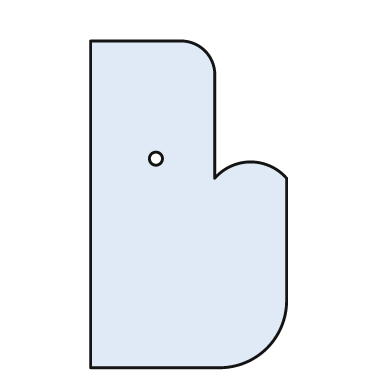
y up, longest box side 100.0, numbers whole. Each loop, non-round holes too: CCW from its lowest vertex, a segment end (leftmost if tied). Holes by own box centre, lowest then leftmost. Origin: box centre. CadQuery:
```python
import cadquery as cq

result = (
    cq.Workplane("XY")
    .moveTo(-30.0, -50.0)
    .lineTo(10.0, -50.0)
    .threePointArc((24.0, -44.0), (30.0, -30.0))
    .lineTo(30.0, 8.0)
    .threePointArc((19.0, 13.0), (8.0, 8.0))
    .lineTo(8.0, 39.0)
    .threePointArc((5.0, 47.0), (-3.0, 50.0))
    .lineTo(-30.0, 50.0)
    .close()
    .moveTo(-10.0, 14.0)
    .circle(2.0)
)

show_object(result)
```